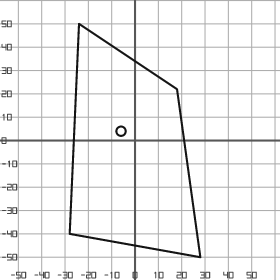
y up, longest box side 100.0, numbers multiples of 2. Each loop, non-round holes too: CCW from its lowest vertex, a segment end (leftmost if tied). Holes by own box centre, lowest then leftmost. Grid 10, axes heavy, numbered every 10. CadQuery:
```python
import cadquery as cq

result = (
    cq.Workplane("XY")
    .moveTo(28.0, -50.0)
    .lineTo(18.0, 22.0)
    .lineTo(-24.0, 50.0)
    .lineTo(-28.0, -40.0)
    .close()
    .moveTo(-6.0, 4.0)
    .circle(2.0)
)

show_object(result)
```